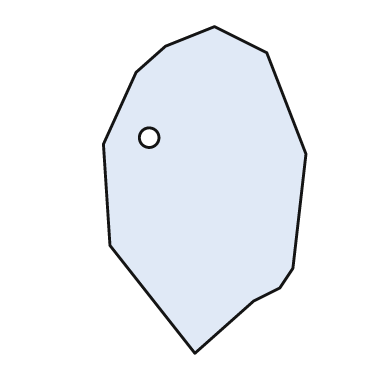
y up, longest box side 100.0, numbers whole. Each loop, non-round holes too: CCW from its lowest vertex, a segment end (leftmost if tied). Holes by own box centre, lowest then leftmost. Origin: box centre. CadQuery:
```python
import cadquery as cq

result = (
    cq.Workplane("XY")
    .moveTo(-3.0, -50.0)
    .lineTo(15.0, -34.0)
    .lineTo(23.0, -30.0)
    .lineTo(27.0, -24.0)
    .lineTo(31.0, 11.0)
    .lineTo(19.0, 42.0)
    .lineTo(3.0, 50.0)
    .lineTo(-12.0, 44.0)
    .lineTo(-21.0, 36.0)
    .lineTo(-31.0, 14.0)
    .lineTo(-29.0, -17.0)
    .close()
    .moveTo(-17.0, 16.0)
    .circle(3.0)
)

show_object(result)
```